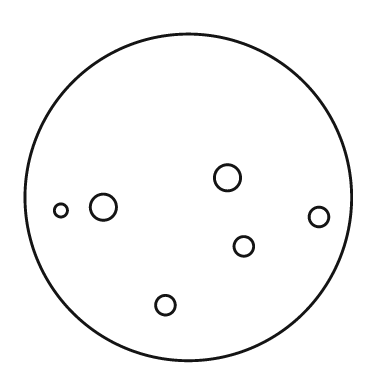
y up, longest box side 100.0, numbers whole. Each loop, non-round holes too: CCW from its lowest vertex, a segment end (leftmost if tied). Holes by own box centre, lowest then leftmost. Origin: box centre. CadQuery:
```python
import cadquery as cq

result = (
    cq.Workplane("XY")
    .moveTo(0.0, 0.0)
    .circle(50.0)
    .moveTo(-7.0, -33.0)
    .circle(3.0)
    .moveTo(17.0, -15.0)
    .circle(3.0)
    .moveTo(40.0, -6.0)
    .circle(3.0)
    .moveTo(-39.0, -4.0)
    .circle(2.0)
    .moveTo(-26.0, -3.0)
    .circle(4.0)
    .moveTo(12.0, 6.0)
    .circle(4.0)
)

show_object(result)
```